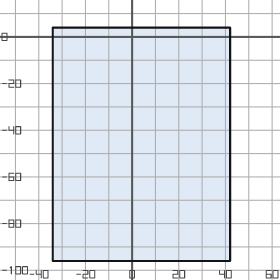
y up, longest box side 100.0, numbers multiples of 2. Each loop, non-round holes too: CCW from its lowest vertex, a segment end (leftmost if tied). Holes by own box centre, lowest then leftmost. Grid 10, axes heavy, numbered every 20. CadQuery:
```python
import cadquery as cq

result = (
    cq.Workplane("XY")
    .moveTo(-34.0, -96.0)
    .lineTo(42.0, -96.0)
    .lineTo(42.0, 4.0)
    .lineTo(-34.0, 4.0)
    .close()
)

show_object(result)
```